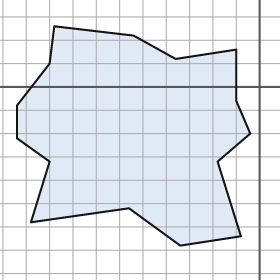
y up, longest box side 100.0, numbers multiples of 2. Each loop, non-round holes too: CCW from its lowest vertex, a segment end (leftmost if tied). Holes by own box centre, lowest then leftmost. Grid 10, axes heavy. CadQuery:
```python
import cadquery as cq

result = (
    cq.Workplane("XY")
    .moveTo(-34.0, -68.0)
    .lineTo(-8.0, -64.0)
    .lineTo(-18.0, -32.0)
    .lineTo(-4.0, -20.0)
    .lineTo(-10.0, -6.0)
    .lineTo(-10.0, 16.0)
    .lineTo(-36.0, 12.0)
    .lineTo(-54.0, 22.0)
    .lineTo(-88.0, 26.0)
    .lineTo(-90.0, 10.0)
    .lineTo(-104.0, -8.0)
    .lineTo(-104.0, -22.0)
    .lineTo(-90.0, -32.0)
    .lineTo(-98.0, -58.0)
    .lineTo(-56.0, -52.0)
    .close()
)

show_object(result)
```